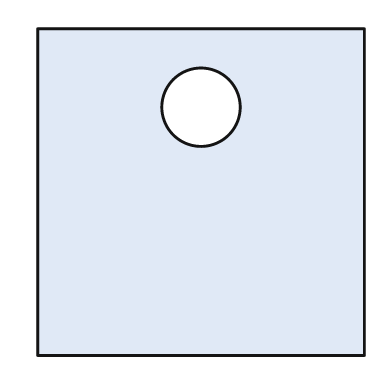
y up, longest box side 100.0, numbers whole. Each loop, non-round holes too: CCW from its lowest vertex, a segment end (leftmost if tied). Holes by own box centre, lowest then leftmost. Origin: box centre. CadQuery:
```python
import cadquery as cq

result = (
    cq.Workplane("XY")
    .moveTo(-50.0, -50.0)
    .lineTo(50.0, -50.0)
    .lineTo(50.0, 50.0)
    .lineTo(-50.0, 50.0)
    .close()
    .moveTo(0.0, 26.0)
    .circle(12.0)
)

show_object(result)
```